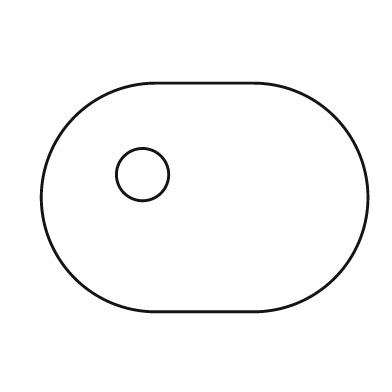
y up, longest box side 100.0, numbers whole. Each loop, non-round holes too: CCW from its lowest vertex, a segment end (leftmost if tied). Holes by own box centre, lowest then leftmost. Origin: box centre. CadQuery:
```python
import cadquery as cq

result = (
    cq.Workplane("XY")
    .moveTo(-15.0, -35.0)
    .lineTo(15.0, -35.0)
    .threePointArc((50.0, 0.0), (15.0, 35.0))
    .lineTo(-15.0, 35.0)
    .threePointArc((-50.0, 0.0), (-15.0, -35.0))
    .close()
    .moveTo(-19.0, 7.0)
    .circle(8.0)
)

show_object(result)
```